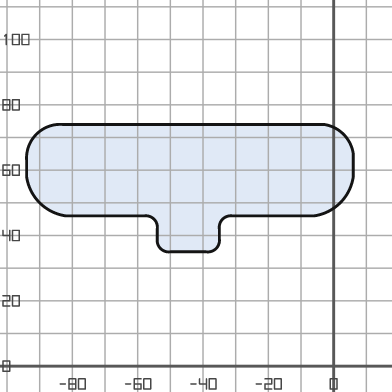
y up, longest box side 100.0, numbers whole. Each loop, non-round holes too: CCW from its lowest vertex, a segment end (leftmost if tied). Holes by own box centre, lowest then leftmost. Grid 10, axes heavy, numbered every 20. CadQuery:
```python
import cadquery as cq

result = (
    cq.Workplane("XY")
    .moveTo(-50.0, 35.0)
    .lineTo(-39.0, 35.0)
    .threePointArc((-36.0, 36.0), (-35.0, 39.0))
    .lineTo(-35.0, 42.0)
    .threePointArc((-34.0, 45.0), (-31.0, 46.0))
    .lineTo(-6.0, 46.0)
    .threePointArc((2.0, 50.0), (6.0, 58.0))
    .lineTo(6.0, 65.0)
    .threePointArc((3.0, 71.0), (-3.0, 74.0))
    .lineTo(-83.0, 74.0)
    .threePointArc((-91.0, 71.0), (-94.0, 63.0))
    .lineTo(-94.0, 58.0)
    .threePointArc((-90.0, 50.0), (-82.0, 46.0))
    .lineTo(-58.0, 46.0)
    .threePointArc((-55.0, 45.0), (-54.0, 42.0))
    .lineTo(-54.0, 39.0)
    .threePointArc((-53.0, 36.0), (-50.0, 35.0))
    .close()
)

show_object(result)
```